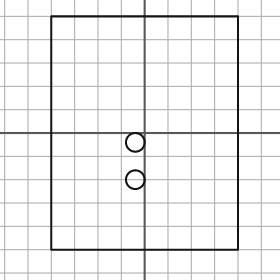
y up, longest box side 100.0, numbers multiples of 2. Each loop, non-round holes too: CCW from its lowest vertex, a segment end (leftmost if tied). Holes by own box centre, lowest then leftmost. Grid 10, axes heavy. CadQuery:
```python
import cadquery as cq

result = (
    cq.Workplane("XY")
    .moveTo(-40.0, -50.0)
    .lineTo(40.0, -50.0)
    .lineTo(40.0, 50.0)
    .lineTo(-40.0, 50.0)
    .close()
    .moveTo(-4.0, -20.0)
    .circle(4.0)
    .moveTo(-4.0, -4.0)
    .circle(4.0)
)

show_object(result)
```